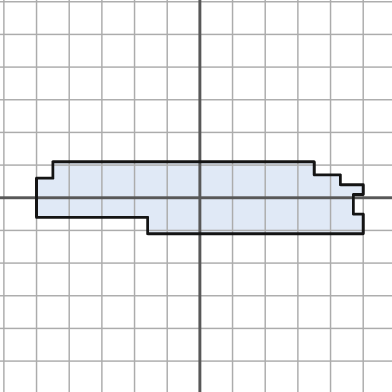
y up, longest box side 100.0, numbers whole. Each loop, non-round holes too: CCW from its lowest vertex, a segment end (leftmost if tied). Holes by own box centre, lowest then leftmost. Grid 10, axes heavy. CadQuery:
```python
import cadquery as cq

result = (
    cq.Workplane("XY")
    .moveTo(-16.0, -11.0)
    .lineTo(50.0, -11.0)
    .lineTo(50.0, -5.0)
    .lineTo(47.0, -5.0)
    .lineTo(47.0, 1.0)
    .lineTo(50.0, 1.0)
    .lineTo(50.0, 4.0)
    .lineTo(43.0, 4.0)
    .lineTo(43.0, 7.0)
    .lineTo(35.0, 7.0)
    .lineTo(35.0, 11.0)
    .lineTo(-45.0, 11.0)
    .lineTo(-45.0, 6.0)
    .lineTo(-50.0, 6.0)
    .lineTo(-50.0, -6.0)
    .lineTo(-16.0, -6.0)
    .close()
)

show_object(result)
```